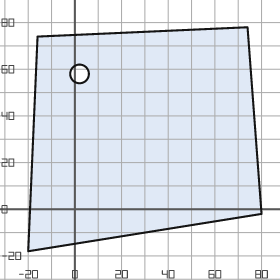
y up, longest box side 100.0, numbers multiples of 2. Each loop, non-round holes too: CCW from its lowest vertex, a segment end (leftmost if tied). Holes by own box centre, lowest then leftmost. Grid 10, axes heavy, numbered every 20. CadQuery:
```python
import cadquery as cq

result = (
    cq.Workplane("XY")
    .moveTo(-20.0, -18.0)
    .lineTo(80.0, -2.0)
    .lineTo(74.0, 78.0)
    .lineTo(-16.0, 74.0)
    .close()
    .moveTo(2.0, 58.0)
    .circle(4.0)
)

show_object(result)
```